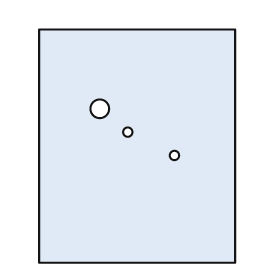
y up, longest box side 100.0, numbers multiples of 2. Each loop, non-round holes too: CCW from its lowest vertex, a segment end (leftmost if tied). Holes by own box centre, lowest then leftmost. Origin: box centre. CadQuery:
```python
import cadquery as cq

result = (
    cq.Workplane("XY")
    .moveTo(-42.0, -50.0)
    .lineTo(42.0, -50.0)
    .lineTo(42.0, 50.0)
    .lineTo(-42.0, 50.0)
    .close()
    .moveTo(16.0, -4.0)
    .circle(2.0)
    .moveTo(-4.0, 6.0)
    .circle(2.0)
    .moveTo(-16.0, 16.0)
    .circle(4.0)
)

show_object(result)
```